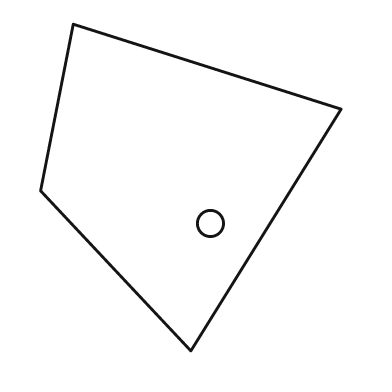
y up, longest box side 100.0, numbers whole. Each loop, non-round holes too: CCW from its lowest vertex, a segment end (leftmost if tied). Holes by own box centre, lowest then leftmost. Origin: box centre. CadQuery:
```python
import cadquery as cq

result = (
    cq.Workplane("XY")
    .moveTo(0.0, -50.0)
    .lineTo(46.0, 24.0)
    .lineTo(-36.0, 50.0)
    .lineTo(-46.0, -1.0)
    .close()
    .moveTo(6.0, -11.0)
    .circle(4.0)
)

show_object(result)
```